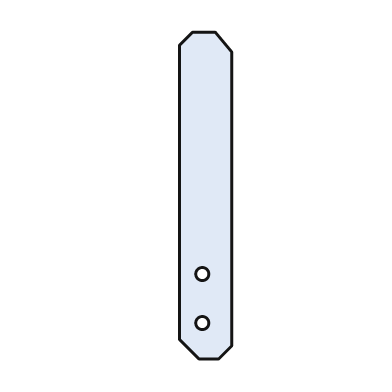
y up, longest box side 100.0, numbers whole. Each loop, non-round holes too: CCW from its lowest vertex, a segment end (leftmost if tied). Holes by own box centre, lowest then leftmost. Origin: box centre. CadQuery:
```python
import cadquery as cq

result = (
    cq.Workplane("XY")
    .moveTo(-2.0, -50.0)
    .lineTo(4.0, -50.0)
    .lineTo(8.0, -46.0)
    .lineTo(8.0, 44.0)
    .lineTo(3.0, 50.0)
    .lineTo(-4.0, 50.0)
    .lineTo(-8.0, 46.0)
    .lineTo(-8.0, -44.0)
    .close()
    .moveTo(-1.0, -39.0)
    .circle(2.0)
    .moveTo(-1.0, -24.0)
    .circle(2.0)
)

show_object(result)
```